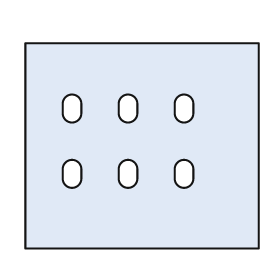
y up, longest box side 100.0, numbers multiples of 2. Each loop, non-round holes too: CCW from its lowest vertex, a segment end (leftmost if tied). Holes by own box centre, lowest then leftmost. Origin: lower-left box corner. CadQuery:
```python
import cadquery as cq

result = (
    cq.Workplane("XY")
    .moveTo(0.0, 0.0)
    .lineTo(100.0, 0.0)
    .lineTo(100.0, 88.0)
    .lineTo(0.0, 88.0)
    .close()
    .moveTo(16.0, 30.0)
    .threePointArc((20.0, 26.0), (24.0, 30.0))
    .lineTo(24.0, 34.0)
    .threePointArc((20.0, 38.0), (16.0, 34.0))
    .close()
    .moveTo(40.0, 30.0)
    .threePointArc((44.0, 26.0), (48.0, 30.0))
    .lineTo(48.0, 34.0)
    .threePointArc((44.0, 38.0), (40.0, 34.0))
    .close()
    .moveTo(64.0, 30.0)
    .threePointArc((68.0, 26.0), (72.0, 30.0))
    .lineTo(72.0, 34.0)
    .threePointArc((68.0, 38.0), (64.0, 34.0))
    .close()
    .moveTo(16.0, 58.0)
    .threePointArc((20.0, 54.0), (24.0, 58.0))
    .lineTo(24.0, 62.0)
    .threePointArc((20.0, 66.0), (16.0, 62.0))
    .close()
    .moveTo(40.0, 58.0)
    .threePointArc((44.0, 54.0), (48.0, 58.0))
    .lineTo(48.0, 62.0)
    .threePointArc((44.0, 66.0), (40.0, 62.0))
    .close()
    .moveTo(64.0, 58.0)
    .threePointArc((68.0, 54.0), (72.0, 58.0))
    .lineTo(72.0, 62.0)
    .threePointArc((68.0, 66.0), (64.0, 62.0))
    .close()
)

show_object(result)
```